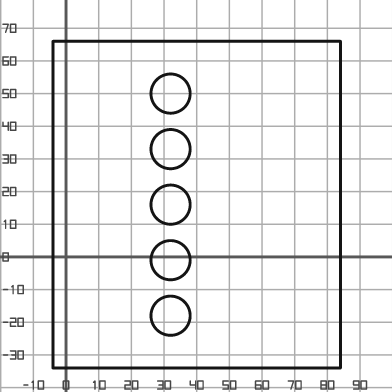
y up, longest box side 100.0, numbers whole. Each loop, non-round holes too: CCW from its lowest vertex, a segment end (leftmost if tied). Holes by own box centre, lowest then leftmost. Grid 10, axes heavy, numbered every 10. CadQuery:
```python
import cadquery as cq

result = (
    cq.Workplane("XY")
    .moveTo(-4.0, -34.0)
    .lineTo(84.0, -34.0)
    .lineTo(84.0, 66.0)
    .lineTo(-4.0, 66.0)
    .close()
    .moveTo(32.0, -18.0)
    .circle(6.0)
    .moveTo(32.0, -1.0)
    .circle(6.0)
    .moveTo(32.0, 16.0)
    .circle(6.0)
    .moveTo(32.0, 33.0)
    .circle(6.0)
    .moveTo(32.0, 50.0)
    .circle(6.0)
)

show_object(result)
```